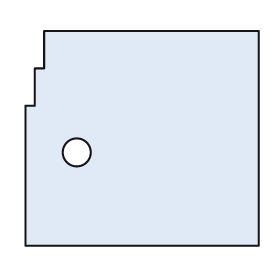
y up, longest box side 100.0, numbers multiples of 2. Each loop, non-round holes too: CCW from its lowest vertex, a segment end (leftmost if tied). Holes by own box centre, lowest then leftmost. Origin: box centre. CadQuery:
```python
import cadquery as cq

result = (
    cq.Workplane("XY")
    .moveTo(-50.0, -46.0)
    .lineTo(50.0, -46.0)
    .lineTo(50.0, 46.0)
    .lineTo(-42.0, 46.0)
    .lineTo(-42.0, 30.0)
    .lineTo(-46.0, 30.0)
    .lineTo(-46.0, 14.0)
    .lineTo(-50.0, 14.0)
    .close()
    .moveTo(-28.0, -6.0)
    .circle(6.0)
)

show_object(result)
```